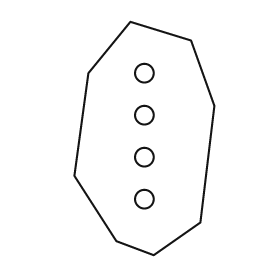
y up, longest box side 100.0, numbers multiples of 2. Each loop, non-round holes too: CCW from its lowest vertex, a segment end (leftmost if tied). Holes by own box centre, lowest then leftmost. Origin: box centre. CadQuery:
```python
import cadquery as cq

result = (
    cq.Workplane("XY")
    .moveTo(4.0, -50.0)
    .lineTo(24.0, -36.0)
    .lineTo(30.0, 14.0)
    .lineTo(20.0, 42.0)
    .lineTo(-6.0, 50.0)
    .lineTo(-24.0, 28.0)
    .lineTo(-30.0, -16.0)
    .lineTo(-12.0, -44.0)
    .close()
    .moveTo(0.0, -26.0)
    .circle(4.0)
    .moveTo(0.0, -8.0)
    .circle(4.0)
    .moveTo(0.0, 10.0)
    .circle(4.0)
    .moveTo(0.0, 28.0)
    .circle(4.0)
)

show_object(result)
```